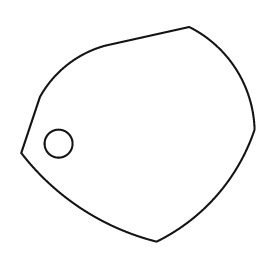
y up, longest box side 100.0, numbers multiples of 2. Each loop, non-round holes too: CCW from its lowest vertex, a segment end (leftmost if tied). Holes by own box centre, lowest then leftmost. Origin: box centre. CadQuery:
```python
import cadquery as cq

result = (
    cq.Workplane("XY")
    .moveTo(8.0, -46.0)
    .threePointArc((34.0, -26.0), (50.0, 2.0))
    .threePointArc((42.0, 28.0), (22.0, 46.0))
    .lineTo(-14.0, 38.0)
    .threePointArc((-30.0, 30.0), (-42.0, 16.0))
    .lineTo(-50.0, -8.0)
    .threePointArc((-24.0, -32.0), (8.0, -46.0))
    .close()
    .moveTo(-34.0, -4.0)
    .circle(6.0)
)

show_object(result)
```